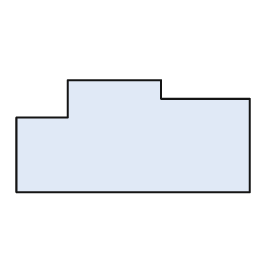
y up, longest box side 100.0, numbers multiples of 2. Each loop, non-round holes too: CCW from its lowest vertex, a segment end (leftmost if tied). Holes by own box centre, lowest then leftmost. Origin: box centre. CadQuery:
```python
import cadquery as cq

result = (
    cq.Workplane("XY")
    .moveTo(-50.0, -24.0)
    .lineTo(50.0, -24.0)
    .lineTo(50.0, 16.0)
    .lineTo(12.0, 16.0)
    .lineTo(12.0, 24.0)
    .lineTo(-28.0, 24.0)
    .lineTo(-28.0, 8.0)
    .lineTo(-50.0, 8.0)
    .close()
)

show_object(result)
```